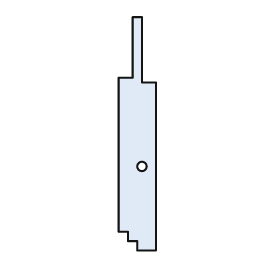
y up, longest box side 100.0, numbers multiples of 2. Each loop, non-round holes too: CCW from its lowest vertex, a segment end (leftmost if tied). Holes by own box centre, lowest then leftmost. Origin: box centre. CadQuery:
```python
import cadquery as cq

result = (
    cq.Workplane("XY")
    .moveTo(0.0, -50.0)
    .lineTo(8.0, -50.0)
    .lineTo(8.0, 22.0)
    .lineTo(2.0, 22.0)
    .lineTo(2.0, 50.0)
    .lineTo(-2.0, 50.0)
    .lineTo(-2.0, 24.0)
    .lineTo(-8.0, 24.0)
    .lineTo(-8.0, -42.0)
    .lineTo(-4.0, -42.0)
    .lineTo(-4.0, -46.0)
    .lineTo(0.0, -46.0)
    .close()
    .moveTo(2.0, -14.0)
    .circle(2.0)
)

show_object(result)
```